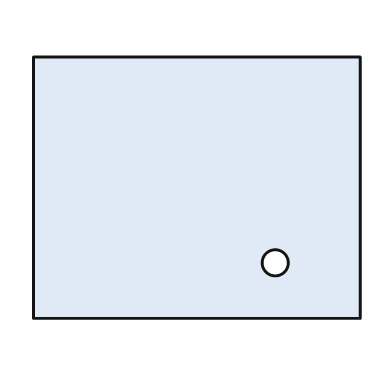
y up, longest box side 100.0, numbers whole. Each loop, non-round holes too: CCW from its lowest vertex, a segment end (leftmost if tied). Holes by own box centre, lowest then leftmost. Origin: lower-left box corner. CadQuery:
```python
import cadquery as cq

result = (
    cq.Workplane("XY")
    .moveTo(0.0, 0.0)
    .lineTo(100.0, 0.0)
    .lineTo(100.0, 80.0)
    .lineTo(0.0, 80.0)
    .close()
    .moveTo(74.0, 17.0)
    .circle(4.0)
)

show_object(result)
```